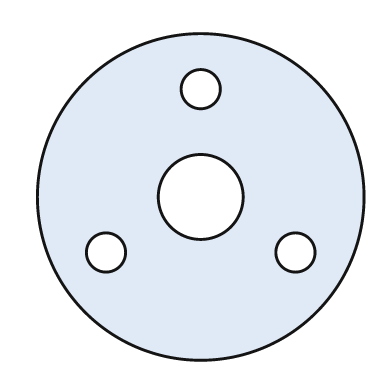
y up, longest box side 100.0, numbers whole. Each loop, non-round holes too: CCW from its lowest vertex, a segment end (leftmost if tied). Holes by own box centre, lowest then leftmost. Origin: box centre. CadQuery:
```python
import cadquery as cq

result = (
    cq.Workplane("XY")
    .moveTo(0.0, 0.0)
    .circle(50.0)
    .moveTo(-29.0, -17.0)
    .circle(6.0)
    .moveTo(29.0, -17.0)
    .circle(6.0)
    .moveTo(0.0, 0.0)
    .circle(13.0)
    .moveTo(0.0, 33.0)
    .circle(6.0)
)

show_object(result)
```